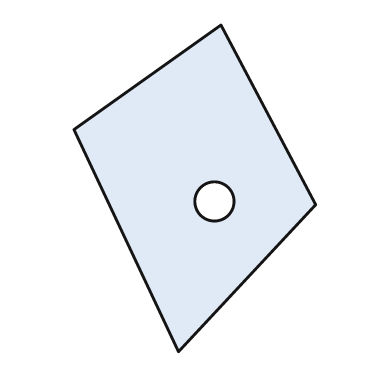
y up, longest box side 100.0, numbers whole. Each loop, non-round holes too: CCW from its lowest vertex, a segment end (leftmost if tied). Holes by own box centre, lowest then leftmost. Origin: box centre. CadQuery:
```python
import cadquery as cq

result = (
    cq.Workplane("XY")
    .moveTo(-5.0, -50.0)
    .lineTo(37.0, -5.0)
    .lineTo(8.0, 50.0)
    .lineTo(-37.0, 18.0)
    .close()
    .moveTo(6.0, -4.0)
    .circle(6.0)
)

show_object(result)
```